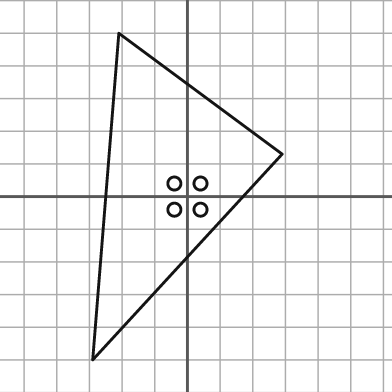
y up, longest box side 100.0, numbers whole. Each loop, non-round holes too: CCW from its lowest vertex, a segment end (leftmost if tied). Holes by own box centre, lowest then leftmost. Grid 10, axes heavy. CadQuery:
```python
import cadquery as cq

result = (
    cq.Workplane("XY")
    .moveTo(-29.0, -50.0)
    .lineTo(29.0, 13.0)
    .lineTo(-21.0, 50.0)
    .close()
    .moveTo(-4.0, -4.0)
    .circle(2.0)
    .moveTo(4.0, -4.0)
    .circle(2.0)
    .moveTo(-4.0, 4.0)
    .circle(2.0)
    .moveTo(4.0, 4.0)
    .circle(2.0)
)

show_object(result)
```